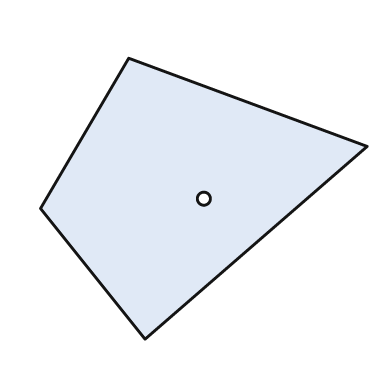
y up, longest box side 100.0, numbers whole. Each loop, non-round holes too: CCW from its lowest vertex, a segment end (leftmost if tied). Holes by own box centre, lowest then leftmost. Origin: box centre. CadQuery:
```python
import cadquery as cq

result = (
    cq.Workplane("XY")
    .moveTo(-18.0, -43.0)
    .lineTo(50.0, 16.0)
    .lineTo(-23.0, 43.0)
    .lineTo(-50.0, -3.0)
    .close()
    .moveTo(0.0, 0.0)
    .circle(2.0)
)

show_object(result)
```